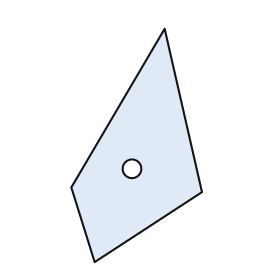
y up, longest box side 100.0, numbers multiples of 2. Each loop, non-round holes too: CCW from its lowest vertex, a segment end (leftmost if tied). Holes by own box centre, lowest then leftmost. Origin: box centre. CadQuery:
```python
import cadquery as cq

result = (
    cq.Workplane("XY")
    .moveTo(-18.0, -50.0)
    .lineTo(28.0, -20.0)
    .lineTo(12.0, 50.0)
    .lineTo(-28.0, -18.0)
    .close()
    .moveTo(-2.0, -10.0)
    .circle(4.0)
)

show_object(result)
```